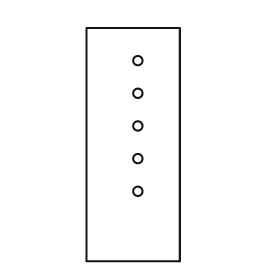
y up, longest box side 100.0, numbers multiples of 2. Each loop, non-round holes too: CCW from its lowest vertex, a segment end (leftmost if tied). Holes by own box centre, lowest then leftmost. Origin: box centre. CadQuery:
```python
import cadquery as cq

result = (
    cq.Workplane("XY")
    .moveTo(-20.0, -50.0)
    .lineTo(20.0, -50.0)
    .lineTo(20.0, 50.0)
    .lineTo(-20.0, 50.0)
    .close()
    .moveTo(2.0, -20.0)
    .circle(2.0)
    .moveTo(2.0, -6.0)
    .circle(2.0)
    .moveTo(2.0, 8.0)
    .circle(2.0)
    .moveTo(2.0, 22.0)
    .circle(2.0)
    .moveTo(2.0, 36.0)
    .circle(2.0)
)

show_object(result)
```